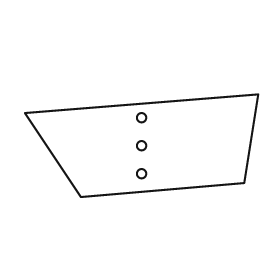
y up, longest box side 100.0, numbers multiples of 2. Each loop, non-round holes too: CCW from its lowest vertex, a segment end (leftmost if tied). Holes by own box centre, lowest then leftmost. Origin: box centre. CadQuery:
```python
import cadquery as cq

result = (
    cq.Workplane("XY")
    .moveTo(-26.0, -22.0)
    .lineTo(44.0, -16.0)
    .lineTo(50.0, 22.0)
    .lineTo(-50.0, 14.0)
    .close()
    .moveTo(0.0, -12.0)
    .circle(2.0)
    .moveTo(0.0, 0.0)
    .circle(2.0)
    .moveTo(0.0, 12.0)
    .circle(2.0)
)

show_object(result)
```